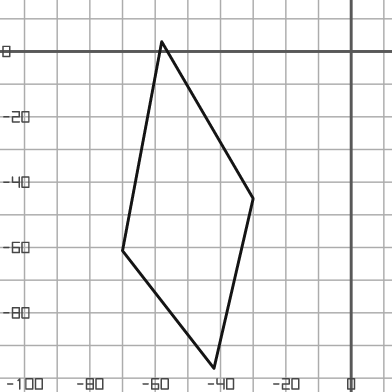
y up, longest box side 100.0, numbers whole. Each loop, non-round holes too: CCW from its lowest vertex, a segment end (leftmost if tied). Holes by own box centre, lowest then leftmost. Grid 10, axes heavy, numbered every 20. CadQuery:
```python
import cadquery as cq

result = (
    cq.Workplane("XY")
    .moveTo(-42.0, -97.0)
    .lineTo(-30.0, -45.0)
    .lineTo(-58.0, 3.0)
    .lineTo(-70.0, -61.0)
    .close()
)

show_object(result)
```